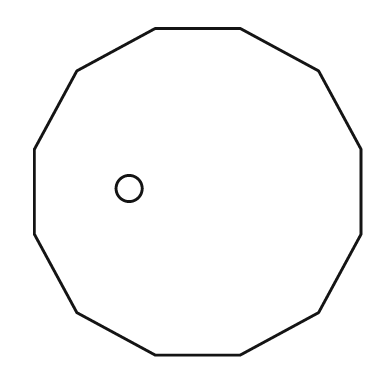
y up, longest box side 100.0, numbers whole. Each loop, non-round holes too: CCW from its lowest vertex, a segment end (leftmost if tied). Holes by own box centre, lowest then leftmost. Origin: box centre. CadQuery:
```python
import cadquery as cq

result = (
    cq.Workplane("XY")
    .moveTo(-13.0, -50.0)
    .lineTo(13.0, -50.0)
    .lineTo(37.0, -37.0)
    .lineTo(50.0, -13.0)
    .lineTo(50.0, 13.0)
    .lineTo(37.0, 37.0)
    .lineTo(13.0, 50.0)
    .lineTo(-13.0, 50.0)
    .lineTo(-37.0, 37.0)
    .lineTo(-50.0, 13.0)
    .lineTo(-50.0, -13.0)
    .lineTo(-37.0, -37.0)
    .close()
    .moveTo(-21.0, 1.0)
    .circle(4.0)
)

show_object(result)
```